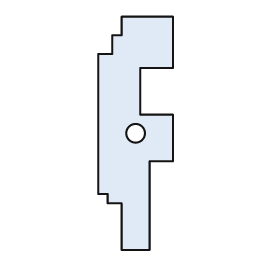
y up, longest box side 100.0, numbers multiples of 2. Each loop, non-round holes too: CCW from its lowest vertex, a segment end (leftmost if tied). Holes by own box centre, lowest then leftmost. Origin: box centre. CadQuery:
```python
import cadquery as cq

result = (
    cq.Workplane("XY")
    .moveTo(-6.0, -50.0)
    .lineTo(6.0, -50.0)
    .lineTo(6.0, -12.0)
    .lineTo(16.0, -12.0)
    .lineTo(16.0, 8.0)
    .lineTo(2.0, 8.0)
    .lineTo(2.0, 28.0)
    .lineTo(16.0, 28.0)
    .lineTo(16.0, 50.0)
    .lineTo(-6.0, 50.0)
    .lineTo(-6.0, 42.0)
    .lineTo(-10.0, 42.0)
    .lineTo(-10.0, 34.0)
    .lineTo(-16.0, 34.0)
    .lineTo(-16.0, -26.0)
    .lineTo(-12.0, -26.0)
    .lineTo(-12.0, -30.0)
    .lineTo(-6.0, -30.0)
    .close()
    .moveTo(0.0, 0.0)
    .circle(4.0)
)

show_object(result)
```